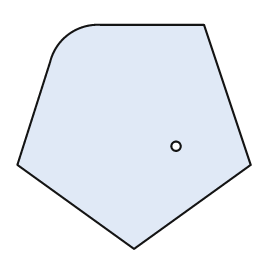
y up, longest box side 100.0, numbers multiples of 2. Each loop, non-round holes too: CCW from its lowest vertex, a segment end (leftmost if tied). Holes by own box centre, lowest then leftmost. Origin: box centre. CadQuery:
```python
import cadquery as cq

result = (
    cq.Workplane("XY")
    .moveTo(0.0, -48.0)
    .lineTo(50.0, -12.0)
    .lineTo(30.0, 48.0)
    .lineTo(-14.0, 48.0)
    .threePointArc((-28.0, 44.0), (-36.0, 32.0))
    .lineTo(-50.0, -12.0)
    .close()
    .moveTo(18.0, -4.0)
    .circle(2.0)
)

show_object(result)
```